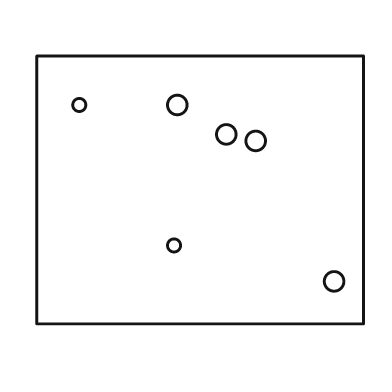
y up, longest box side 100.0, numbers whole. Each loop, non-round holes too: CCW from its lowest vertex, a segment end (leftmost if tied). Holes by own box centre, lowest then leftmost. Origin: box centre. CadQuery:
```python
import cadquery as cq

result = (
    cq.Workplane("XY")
    .moveTo(-50.0, -41.0)
    .lineTo(50.0, -41.0)
    .lineTo(50.0, 41.0)
    .lineTo(-50.0, 41.0)
    .close()
    .moveTo(41.0, -28.0)
    .circle(3.0)
    .moveTo(-8.0, -17.0)
    .circle(2.0)
    .moveTo(17.0, 15.0)
    .circle(3.0)
    .moveTo(8.0, 17.0)
    .circle(3.0)
    .moveTo(-37.0, 26.0)
    .circle(2.0)
    .moveTo(-7.0, 26.0)
    .circle(3.0)
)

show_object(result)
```